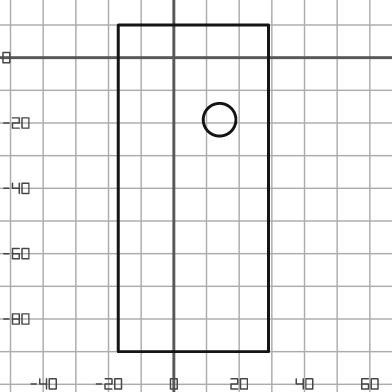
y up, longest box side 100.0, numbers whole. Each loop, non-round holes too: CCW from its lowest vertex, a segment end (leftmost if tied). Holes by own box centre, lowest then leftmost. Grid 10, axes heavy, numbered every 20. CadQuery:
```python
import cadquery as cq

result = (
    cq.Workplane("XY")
    .moveTo(-17.0, -90.0)
    .lineTo(29.0, -90.0)
    .lineTo(29.0, 10.0)
    .lineTo(-17.0, 10.0)
    .close()
    .moveTo(14.0, -19.0)
    .circle(5.0)
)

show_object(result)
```